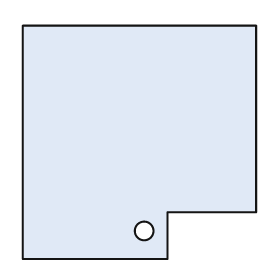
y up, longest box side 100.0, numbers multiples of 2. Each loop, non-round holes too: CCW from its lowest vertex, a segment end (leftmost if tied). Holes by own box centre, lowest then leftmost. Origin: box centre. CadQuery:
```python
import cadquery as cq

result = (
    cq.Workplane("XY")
    .moveTo(-50.0, -50.0)
    .lineTo(12.0, -50.0)
    .lineTo(12.0, -30.0)
    .lineTo(50.0, -30.0)
    .lineTo(50.0, 50.0)
    .lineTo(-50.0, 50.0)
    .close()
    .moveTo(2.0, -38.0)
    .circle(4.0)
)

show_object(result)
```